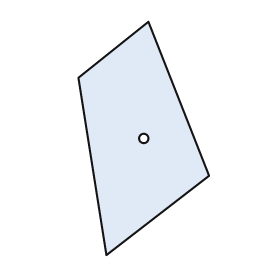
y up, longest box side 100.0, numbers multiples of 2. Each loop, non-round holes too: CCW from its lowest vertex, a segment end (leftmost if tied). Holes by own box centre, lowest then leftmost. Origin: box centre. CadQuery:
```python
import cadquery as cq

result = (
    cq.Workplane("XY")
    .moveTo(-16.0, -50.0)
    .lineTo(28.0, -16.0)
    .lineTo(2.0, 50.0)
    .lineTo(-28.0, 26.0)
    .close()
    .moveTo(0.0, 0.0)
    .circle(2.0)
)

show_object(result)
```